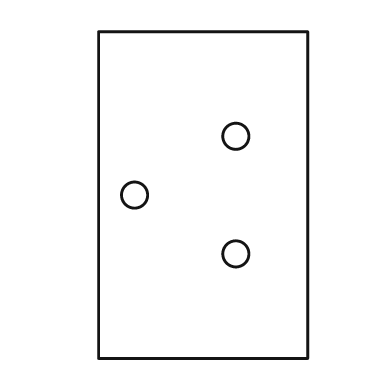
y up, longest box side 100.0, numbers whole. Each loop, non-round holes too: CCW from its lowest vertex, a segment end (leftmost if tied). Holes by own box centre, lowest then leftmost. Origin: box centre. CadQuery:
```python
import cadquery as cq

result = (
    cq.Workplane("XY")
    .moveTo(-32.0, -50.0)
    .lineTo(32.0, -50.0)
    .lineTo(32.0, 50.0)
    .lineTo(-32.0, 50.0)
    .close()
    .moveTo(10.0, -18.0)
    .circle(4.0)
    .moveTo(-21.0, 0.0)
    .circle(4.0)
    .moveTo(10.0, 18.0)
    .circle(4.0)
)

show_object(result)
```